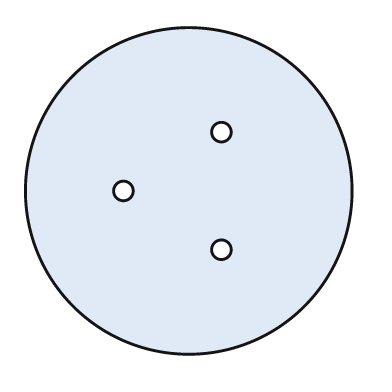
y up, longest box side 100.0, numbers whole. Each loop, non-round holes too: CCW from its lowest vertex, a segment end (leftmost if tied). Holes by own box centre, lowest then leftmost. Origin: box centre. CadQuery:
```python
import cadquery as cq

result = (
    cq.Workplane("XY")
    .moveTo(0.0, 0.0)
    .circle(50.0)
    .moveTo(10.0, -18.0)
    .circle(3.0)
    .moveTo(-20.0, 0.0)
    .circle(3.0)
    .moveTo(10.0, 18.0)
    .circle(3.0)
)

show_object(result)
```